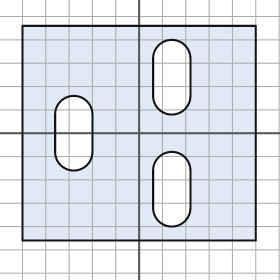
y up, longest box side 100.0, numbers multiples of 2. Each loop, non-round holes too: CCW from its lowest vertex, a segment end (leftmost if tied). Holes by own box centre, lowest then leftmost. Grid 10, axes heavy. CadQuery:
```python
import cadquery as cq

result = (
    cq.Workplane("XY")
    .moveTo(-50.0, -46.0)
    .lineTo(50.0, -46.0)
    .lineTo(50.0, 46.0)
    .lineTo(-50.0, 46.0)
    .close()
    .moveTo(6.0, -32.0)
    .threePointArc((14.0, -40.0), (22.0, -32.0))
    .lineTo(22.0, -16.0)
    .threePointArc((14.0, -8.0), (6.0, -16.0))
    .close()
    .moveTo(-36.0, -8.0)
    .threePointArc((-28.0, -16.0), (-20.0, -8.0))
    .lineTo(-20.0, 8.0)
    .threePointArc((-28.0, 16.0), (-36.0, 8.0))
    .close()
    .moveTo(6.0, 16.0)
    .threePointArc((14.0, 8.0), (22.0, 16.0))
    .lineTo(22.0, 32.0)
    .threePointArc((14.0, 40.0), (6.0, 32.0))
    .close()
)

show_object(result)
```